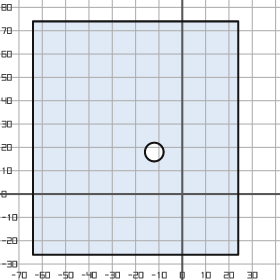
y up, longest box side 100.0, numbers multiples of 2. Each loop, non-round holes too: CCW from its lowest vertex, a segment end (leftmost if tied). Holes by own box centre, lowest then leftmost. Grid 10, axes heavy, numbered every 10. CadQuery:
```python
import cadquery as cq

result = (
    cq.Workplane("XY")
    .moveTo(-64.0, -26.0)
    .lineTo(24.0, -26.0)
    .lineTo(24.0, 74.0)
    .lineTo(-64.0, 74.0)
    .close()
    .moveTo(-12.0, 18.0)
    .circle(4.0)
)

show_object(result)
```